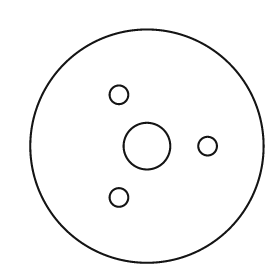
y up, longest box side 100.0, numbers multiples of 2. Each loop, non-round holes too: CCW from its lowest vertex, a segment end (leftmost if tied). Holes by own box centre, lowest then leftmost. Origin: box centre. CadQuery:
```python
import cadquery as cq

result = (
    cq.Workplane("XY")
    .moveTo(0.0, 0.0)
    .circle(50.0)
    .moveTo(-12.0, -22.0)
    .circle(4.0)
    .moveTo(0.0, 0.0)
    .circle(10.0)
    .moveTo(26.0, 0.0)
    .circle(4.0)
    .moveTo(-12.0, 22.0)
    .circle(4.0)
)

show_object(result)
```